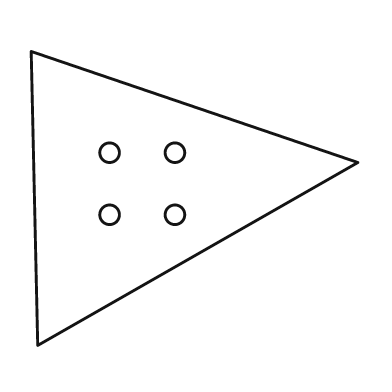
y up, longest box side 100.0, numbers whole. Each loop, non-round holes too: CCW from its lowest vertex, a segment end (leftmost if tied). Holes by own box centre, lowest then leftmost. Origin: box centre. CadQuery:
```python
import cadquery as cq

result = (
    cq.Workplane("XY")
    .moveTo(-48.0, -45.0)
    .lineTo(50.0, 11.0)
    .lineTo(-50.0, 45.0)
    .close()
    .moveTo(-26.0, -5.0)
    .circle(3.0)
    .moveTo(-6.0, -5.0)
    .circle(3.0)
    .moveTo(-26.0, 14.0)
    .circle(3.0)
    .moveTo(-6.0, 14.0)
    .circle(3.0)
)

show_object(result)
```